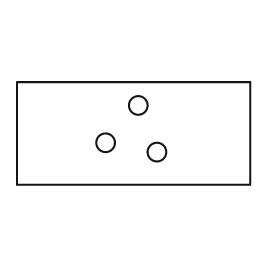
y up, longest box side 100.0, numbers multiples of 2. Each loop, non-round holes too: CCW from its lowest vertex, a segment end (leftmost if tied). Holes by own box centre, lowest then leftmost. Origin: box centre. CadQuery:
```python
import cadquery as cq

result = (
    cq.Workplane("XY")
    .moveTo(-50.0, -22.0)
    .lineTo(50.0, -22.0)
    .lineTo(50.0, 22.0)
    .lineTo(-50.0, 22.0)
    .close()
    .moveTo(10.0, -8.0)
    .circle(4.0)
    .moveTo(-12.0, -4.0)
    .circle(4.0)
    .moveTo(2.0, 12.0)
    .circle(4.0)
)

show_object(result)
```